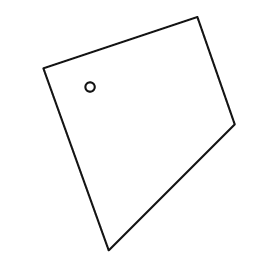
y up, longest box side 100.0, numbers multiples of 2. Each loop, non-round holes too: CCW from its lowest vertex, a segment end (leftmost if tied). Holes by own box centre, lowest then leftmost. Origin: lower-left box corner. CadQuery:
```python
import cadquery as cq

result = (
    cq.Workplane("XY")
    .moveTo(28.0, 0.0)
    .lineTo(82.0, 54.0)
    .lineTo(66.0, 100.0)
    .lineTo(0.0, 78.0)
    .close()
    .moveTo(20.0, 70.0)
    .circle(2.0)
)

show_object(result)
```